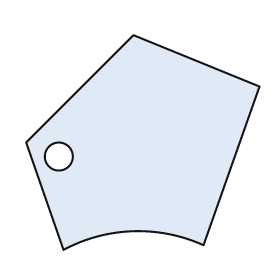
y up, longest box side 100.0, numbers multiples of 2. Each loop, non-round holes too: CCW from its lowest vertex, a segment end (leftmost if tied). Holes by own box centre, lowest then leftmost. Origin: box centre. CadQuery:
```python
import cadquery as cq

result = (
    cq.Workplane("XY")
    .moveTo(-34.0, -46.0)
    .threePointArc((-4.0, -38.0), (26.0, -44.0))
    .lineTo(50.0, 24.0)
    .lineTo(-4.0, 46.0)
    .lineTo(-50.0, 0.0)
    .close()
    .moveTo(-36.0, -6.0)
    .circle(6.0)
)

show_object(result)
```